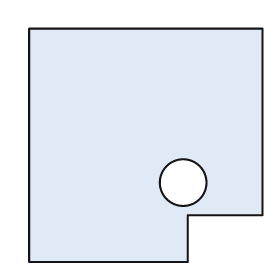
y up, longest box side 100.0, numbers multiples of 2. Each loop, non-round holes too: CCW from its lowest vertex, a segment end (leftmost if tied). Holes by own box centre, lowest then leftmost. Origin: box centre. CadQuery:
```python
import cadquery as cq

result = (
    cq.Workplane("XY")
    .moveTo(-50.0, -50.0)
    .lineTo(18.0, -50.0)
    .lineTo(18.0, -30.0)
    .lineTo(50.0, -30.0)
    .lineTo(50.0, 50.0)
    .lineTo(-50.0, 50.0)
    .close()
    .moveTo(16.0, -16.0)
    .circle(10.0)
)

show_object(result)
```